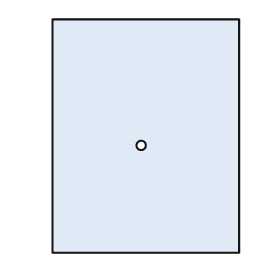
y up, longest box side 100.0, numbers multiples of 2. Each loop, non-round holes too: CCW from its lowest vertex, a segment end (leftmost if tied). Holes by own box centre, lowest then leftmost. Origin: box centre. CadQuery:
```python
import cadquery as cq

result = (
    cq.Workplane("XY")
    .moveTo(-40.0, -50.0)
    .lineTo(40.0, -50.0)
    .lineTo(40.0, 50.0)
    .lineTo(-40.0, 50.0)
    .close()
    .moveTo(-2.0, -4.0)
    .circle(2.0)
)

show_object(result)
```